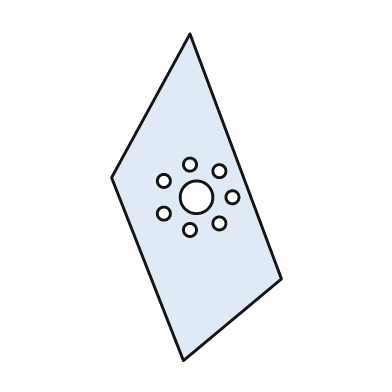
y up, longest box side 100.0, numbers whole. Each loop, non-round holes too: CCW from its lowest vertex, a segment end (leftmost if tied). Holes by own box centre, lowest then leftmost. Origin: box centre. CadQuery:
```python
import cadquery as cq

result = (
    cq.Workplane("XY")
    .moveTo(-4.0, -50.0)
    .lineTo(26.0, -25.0)
    .lineTo(-2.0, 50.0)
    .lineTo(-26.0, 6.0)
    .close()
    .moveTo(-2.0, -10.0)
    .circle(2.0)
    .moveTo(7.0, -8.0)
    .circle(2.0)
    .moveTo(-10.0, -5.0)
    .circle(2.0)
    .moveTo(0.0, 0.0)
    .circle(5.0)
    .moveTo(11.0, 0.0)
    .circle(2.0)
    .moveTo(-10.0, 5.0)
    .circle(2.0)
    .moveTo(7.0, 8.0)
    .circle(2.0)
    .moveTo(-2.0, 10.0)
    .circle(2.0)
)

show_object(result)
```